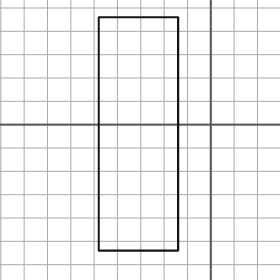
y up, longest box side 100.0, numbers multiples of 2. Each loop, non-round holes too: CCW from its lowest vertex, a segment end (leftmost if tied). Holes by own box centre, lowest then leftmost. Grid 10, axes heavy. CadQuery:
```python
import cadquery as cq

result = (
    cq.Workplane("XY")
    .moveTo(-48.0, -54.0)
    .lineTo(-14.0, -54.0)
    .lineTo(-14.0, 46.0)
    .lineTo(-48.0, 46.0)
    .close()
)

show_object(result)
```